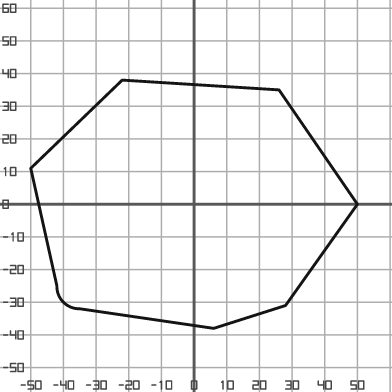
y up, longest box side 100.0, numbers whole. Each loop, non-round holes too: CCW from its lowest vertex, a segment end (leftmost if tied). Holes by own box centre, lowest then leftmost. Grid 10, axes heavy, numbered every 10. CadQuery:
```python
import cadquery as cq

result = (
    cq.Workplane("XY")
    .moveTo(6.0, -38.0)
    .lineTo(28.0, -31.0)
    .lineTo(50.0, 0.0)
    .lineTo(26.0, 35.0)
    .lineTo(-22.0, 38.0)
    .lineTo(-50.0, 11.0)
    .lineTo(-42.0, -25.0)
    .threePointArc((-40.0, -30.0), (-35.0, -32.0))
    .close()
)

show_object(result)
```